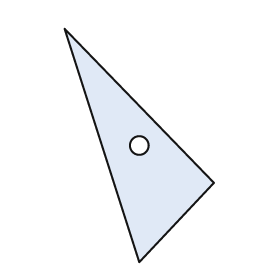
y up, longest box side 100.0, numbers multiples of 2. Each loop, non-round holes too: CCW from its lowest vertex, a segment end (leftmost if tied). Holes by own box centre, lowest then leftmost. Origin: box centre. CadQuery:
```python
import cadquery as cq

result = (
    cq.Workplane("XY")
    .moveTo(0.0, -50.0)
    .lineTo(32.0, -16.0)
    .lineTo(-32.0, 50.0)
    .close()
    .moveTo(0.0, 0.0)
    .circle(4.0)
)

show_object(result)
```